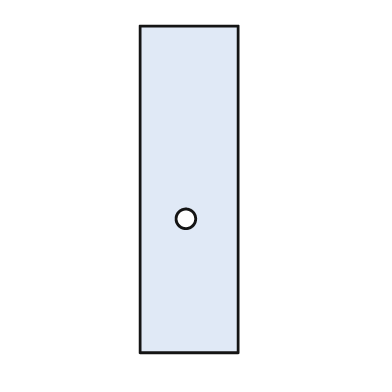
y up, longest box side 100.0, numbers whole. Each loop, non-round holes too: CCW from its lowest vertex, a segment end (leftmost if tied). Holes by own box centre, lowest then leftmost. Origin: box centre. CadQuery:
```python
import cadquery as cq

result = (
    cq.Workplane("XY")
    .moveTo(-15.0, -50.0)
    .lineTo(15.0, -50.0)
    .lineTo(15.0, 50.0)
    .lineTo(-15.0, 50.0)
    .close()
    .moveTo(-1.0, -9.0)
    .circle(3.0)
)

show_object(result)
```